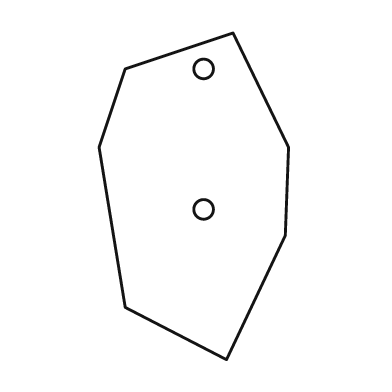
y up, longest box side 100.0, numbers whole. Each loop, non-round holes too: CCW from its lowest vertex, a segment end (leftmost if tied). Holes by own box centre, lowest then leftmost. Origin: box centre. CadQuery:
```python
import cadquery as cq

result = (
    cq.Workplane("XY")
    .moveTo(10.0, -50.0)
    .lineTo(28.0, -12.0)
    .lineTo(29.0, 15.0)
    .lineTo(12.0, 50.0)
    .lineTo(-21.0, 39.0)
    .lineTo(-29.0, 15.0)
    .lineTo(-21.0, -34.0)
    .close()
    .moveTo(3.0, -4.0)
    .circle(3.0)
    .moveTo(3.0, 39.0)
    .circle(3.0)
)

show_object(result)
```